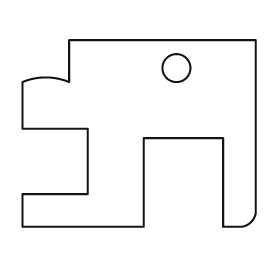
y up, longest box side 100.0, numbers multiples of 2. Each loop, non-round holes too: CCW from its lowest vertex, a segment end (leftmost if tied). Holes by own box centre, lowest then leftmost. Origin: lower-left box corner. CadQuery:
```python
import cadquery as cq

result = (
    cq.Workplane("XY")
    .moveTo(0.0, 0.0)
    .lineTo(52.0, 0.0)
    .lineTo(52.0, 38.0)
    .lineTo(86.0, 38.0)
    .lineTo(86.0, 0.0)
    .lineTo(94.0, 0.0)
    .threePointArc((98.0, 2.0), (100.0, 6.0))
    .lineTo(100.0, 80.0)
    .lineTo(20.0, 80.0)
    .lineTo(20.0, 62.0)
    .threePointArc((10.0, 64.0), (0.0, 62.0))
    .lineTo(0.0, 42.0)
    .lineTo(28.0, 42.0)
    .lineTo(28.0, 14.0)
    .lineTo(0.0, 14.0)
    .close()
    .moveTo(66.0, 68.0)
    .circle(6.0)
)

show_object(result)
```